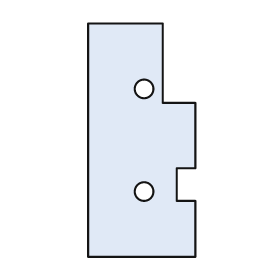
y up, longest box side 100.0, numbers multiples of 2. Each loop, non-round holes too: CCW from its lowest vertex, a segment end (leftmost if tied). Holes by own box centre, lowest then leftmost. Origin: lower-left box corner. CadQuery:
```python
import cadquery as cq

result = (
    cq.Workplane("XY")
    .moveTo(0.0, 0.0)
    .lineTo(46.0, 0.0)
    .lineTo(46.0, 24.0)
    .lineTo(38.0, 24.0)
    .lineTo(38.0, 38.0)
    .lineTo(46.0, 38.0)
    .lineTo(46.0, 66.0)
    .lineTo(32.0, 66.0)
    .lineTo(32.0, 100.0)
    .lineTo(0.0, 100.0)
    .close()
    .moveTo(24.0, 28.0)
    .circle(4.0)
    .moveTo(24.0, 72.0)
    .circle(4.0)
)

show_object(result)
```